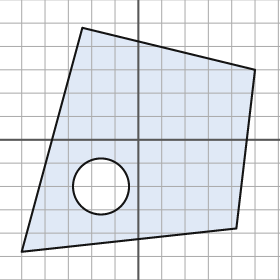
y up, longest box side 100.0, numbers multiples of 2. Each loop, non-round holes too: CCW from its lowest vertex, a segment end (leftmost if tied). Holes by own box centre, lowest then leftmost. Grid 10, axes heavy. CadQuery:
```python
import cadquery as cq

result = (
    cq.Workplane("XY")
    .moveTo(-50.0, -48.0)
    .lineTo(42.0, -38.0)
    .lineTo(50.0, 30.0)
    .lineTo(-24.0, 48.0)
    .close()
    .moveTo(-16.0, -20.0)
    .circle(12.0)
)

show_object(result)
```